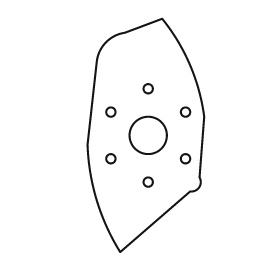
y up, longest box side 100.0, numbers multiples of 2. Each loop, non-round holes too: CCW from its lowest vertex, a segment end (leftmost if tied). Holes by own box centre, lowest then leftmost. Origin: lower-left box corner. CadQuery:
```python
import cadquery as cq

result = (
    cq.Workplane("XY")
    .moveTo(14.0, 0.0)
    .lineTo(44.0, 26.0)
    .threePointArc((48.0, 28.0), (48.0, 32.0))
    .lineTo(50.0, 58.0)
    .threePointArc((44.0, 80.0), (32.0, 100.0))
    .lineTo(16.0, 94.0)
    .threePointArc((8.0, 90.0), (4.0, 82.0))
    .lineTo(0.0, 46.0)
    .threePointArc((4.0, 22.0), (14.0, 0.0))
    .close()
    .moveTo(26.0, 30.0)
    .circle(2.0)
    .moveTo(10.0, 40.0)
    .circle(2.0)
    .moveTo(42.0, 40.0)
    .circle(2.0)
    .moveTo(26.0, 50.0)
    .circle(8.0)
    .moveTo(10.0, 60.0)
    .circle(2.0)
    .moveTo(42.0, 60.0)
    .circle(2.0)
    .moveTo(26.0, 70.0)
    .circle(2.0)
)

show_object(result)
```